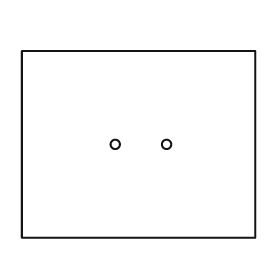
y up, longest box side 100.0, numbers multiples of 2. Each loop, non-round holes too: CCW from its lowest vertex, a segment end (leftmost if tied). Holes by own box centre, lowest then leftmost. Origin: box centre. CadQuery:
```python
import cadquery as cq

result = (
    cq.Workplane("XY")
    .moveTo(-50.0, -40.0)
    .lineTo(50.0, -40.0)
    .lineTo(50.0, 40.0)
    .lineTo(-50.0, 40.0)
    .close()
    .moveTo(-10.0, 0.0)
    .circle(2.0)
    .moveTo(12.0, 0.0)
    .circle(2.0)
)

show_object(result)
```